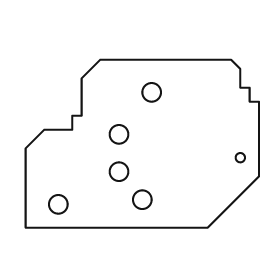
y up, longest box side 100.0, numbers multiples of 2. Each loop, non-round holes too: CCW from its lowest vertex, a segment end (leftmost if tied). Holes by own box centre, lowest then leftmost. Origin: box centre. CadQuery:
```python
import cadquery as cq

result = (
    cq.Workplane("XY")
    .moveTo(-50.0, -36.0)
    .lineTo(28.0, -36.0)
    .lineTo(50.0, -14.0)
    .lineTo(50.0, 18.0)
    .lineTo(46.0, 18.0)
    .lineTo(46.0, 24.0)
    .lineTo(42.0, 24.0)
    .lineTo(42.0, 32.0)
    .lineTo(38.0, 36.0)
    .lineTo(-18.0, 36.0)
    .lineTo(-26.0, 28.0)
    .lineTo(-26.0, 12.0)
    .lineTo(-30.0, 12.0)
    .lineTo(-30.0, 6.0)
    .lineTo(-42.0, 6.0)
    .lineTo(-50.0, -2.0)
    .close()
    .moveTo(-36.0, -26.0)
    .circle(4.0)
    .moveTo(0.0, -24.0)
    .circle(4.0)
    .moveTo(-10.0, -12.0)
    .circle(4.0)
    .moveTo(42.0, -6.0)
    .circle(2.0)
    .moveTo(-10.0, 4.0)
    .circle(4.0)
    .moveTo(4.0, 22.0)
    .circle(4.0)
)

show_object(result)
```